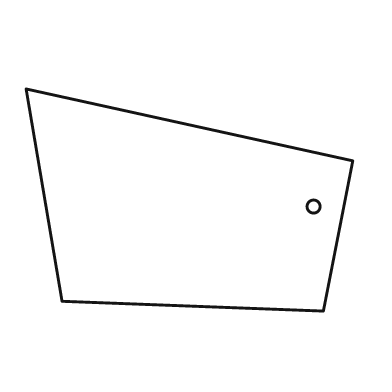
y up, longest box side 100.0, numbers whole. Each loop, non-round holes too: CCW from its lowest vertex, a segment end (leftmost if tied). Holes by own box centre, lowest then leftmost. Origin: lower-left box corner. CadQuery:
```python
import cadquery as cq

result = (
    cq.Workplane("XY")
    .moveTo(91.0, 0.0)
    .lineTo(100.0, 46.0)
    .lineTo(0.0, 68.0)
    .lineTo(11.0, 3.0)
    .close()
    .moveTo(88.0, 32.0)
    .circle(2.0)
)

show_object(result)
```